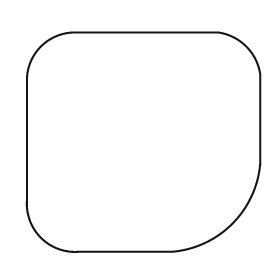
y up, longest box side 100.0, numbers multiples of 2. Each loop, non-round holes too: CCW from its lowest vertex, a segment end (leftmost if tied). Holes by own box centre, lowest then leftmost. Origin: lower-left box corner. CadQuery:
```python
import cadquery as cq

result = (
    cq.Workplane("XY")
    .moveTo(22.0, 0.0)
    .lineTo(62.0, 0.0)
    .threePointArc((88.0, 12.0), (100.0, 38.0))
    .lineTo(100.0, 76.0)
    .threePointArc((94.0, 88.0), (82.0, 94.0))
    .lineTo(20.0, 94.0)
    .threePointArc((6.0, 88.0), (0.0, 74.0))
    .lineTo(0.0, 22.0)
    .threePointArc((6.0, 6.0), (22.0, 0.0))
    .close()
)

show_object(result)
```